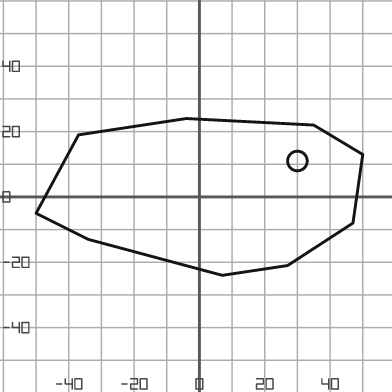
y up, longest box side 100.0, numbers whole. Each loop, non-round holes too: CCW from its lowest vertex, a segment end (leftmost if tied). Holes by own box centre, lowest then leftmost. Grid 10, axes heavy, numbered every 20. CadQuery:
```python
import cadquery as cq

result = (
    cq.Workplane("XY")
    .moveTo(7.0, -24.0)
    .lineTo(27.0, -21.0)
    .lineTo(47.0, -8.0)
    .lineTo(50.0, 13.0)
    .lineTo(35.0, 22.0)
    .lineTo(-4.0, 24.0)
    .lineTo(-37.0, 19.0)
    .lineTo(-50.0, -5.0)
    .lineTo(-34.0, -13.0)
    .close()
    .moveTo(30.0, 11.0)
    .circle(3.0)
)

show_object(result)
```